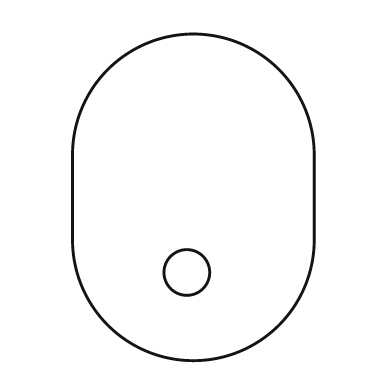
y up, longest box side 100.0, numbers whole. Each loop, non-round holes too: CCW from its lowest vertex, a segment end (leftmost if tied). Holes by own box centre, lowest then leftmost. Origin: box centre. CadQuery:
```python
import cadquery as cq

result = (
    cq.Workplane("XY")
    .moveTo(-37.0, -13.0)
    .threePointArc((0.0, -50.0), (37.0, -13.0))
    .lineTo(37.0, 13.0)
    .threePointArc((0.0, 50.0), (-37.0, 13.0))
    .close()
    .moveTo(-2.0, -23.0)
    .circle(7.0)
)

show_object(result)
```